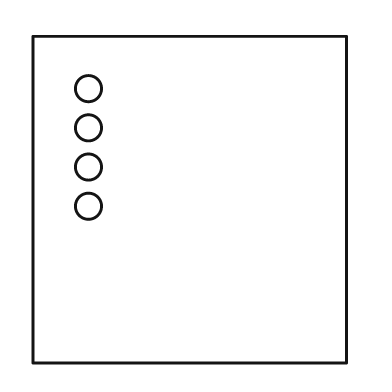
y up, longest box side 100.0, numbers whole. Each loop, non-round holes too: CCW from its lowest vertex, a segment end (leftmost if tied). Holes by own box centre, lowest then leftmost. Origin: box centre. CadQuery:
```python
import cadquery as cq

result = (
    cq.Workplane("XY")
    .moveTo(-48.0, -50.0)
    .lineTo(48.0, -50.0)
    .lineTo(48.0, 50.0)
    .lineTo(-48.0, 50.0)
    .close()
    .moveTo(-31.0, -2.0)
    .circle(4.0)
    .moveTo(-31.0, 10.0)
    .circle(4.0)
    .moveTo(-31.0, 22.0)
    .circle(4.0)
    .moveTo(-31.0, 34.0)
    .circle(4.0)
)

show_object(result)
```